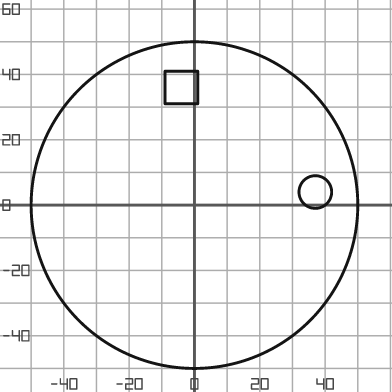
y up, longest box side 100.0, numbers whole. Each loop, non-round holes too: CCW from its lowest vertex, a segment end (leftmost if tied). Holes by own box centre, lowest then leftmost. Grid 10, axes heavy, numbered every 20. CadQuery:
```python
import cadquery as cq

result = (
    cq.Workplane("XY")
    .moveTo(0.0, 0.0)
    .circle(50.0)
    .moveTo(37.0, 4.0)
    .circle(5.0)
    .moveTo(-9.0, 31.0)
    .lineTo(1.0, 31.0)
    .lineTo(1.0, 41.0)
    .lineTo(-9.0, 41.0)
    .close()
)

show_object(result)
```